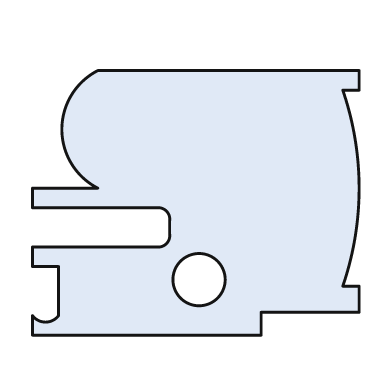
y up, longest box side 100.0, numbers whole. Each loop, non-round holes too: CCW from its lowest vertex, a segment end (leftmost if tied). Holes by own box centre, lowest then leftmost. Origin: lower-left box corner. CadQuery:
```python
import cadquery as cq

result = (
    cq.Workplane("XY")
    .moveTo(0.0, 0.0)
    .lineTo(70.0, 0.0)
    .lineTo(70.0, 7.0)
    .lineTo(100.0, 7.0)
    .lineTo(100.0, 15.0)
    .lineTo(95.0, 15.0)
    .threePointArc((100.0, 45.0), (95.0, 75.0))
    .lineTo(100.0, 75.0)
    .lineTo(100.0, 81.0)
    .lineTo(20.0, 81.0)
    .threePointArc((9.0, 63.0), (20.0, 45.0))
    .lineTo(0.0, 45.0)
    .lineTo(0.0, 39.0)
    .lineTo(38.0, 39.0)
    .threePointArc((41.0, 38.0), (42.0, 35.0))
    .lineTo(42.0, 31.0)
    .threePointArc((41.0, 28.0), (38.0, 27.0))
    .lineTo(0.0, 27.0)
    .lineTo(0.0, 21.0)
    .lineTo(8.0, 21.0)
    .lineTo(8.0, 6.0)
    .threePointArc((4.0, 4.0), (0.0, 6.0))
    .close()
    .moveTo(51.0, 17.0)
    .circle(8.0)
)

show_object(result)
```